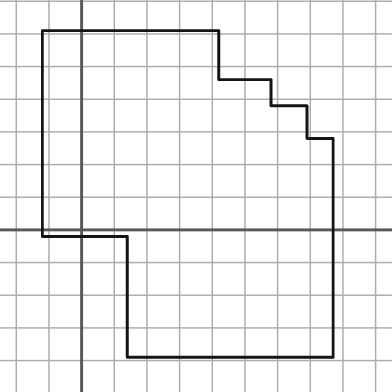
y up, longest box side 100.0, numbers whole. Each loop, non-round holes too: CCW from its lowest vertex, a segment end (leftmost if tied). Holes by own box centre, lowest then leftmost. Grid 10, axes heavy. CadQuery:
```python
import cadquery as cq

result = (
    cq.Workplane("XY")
    .moveTo(14.0, -39.0)
    .lineTo(77.0, -39.0)
    .lineTo(77.0, 28.0)
    .lineTo(69.0, 28.0)
    .lineTo(69.0, 38.0)
    .lineTo(58.0, 38.0)
    .lineTo(58.0, 46.0)
    .lineTo(42.0, 46.0)
    .lineTo(42.0, 61.0)
    .lineTo(-12.0, 61.0)
    .lineTo(-12.0, -2.0)
    .lineTo(14.0, -2.0)
    .close()
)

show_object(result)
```